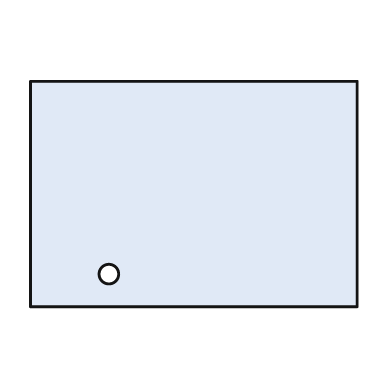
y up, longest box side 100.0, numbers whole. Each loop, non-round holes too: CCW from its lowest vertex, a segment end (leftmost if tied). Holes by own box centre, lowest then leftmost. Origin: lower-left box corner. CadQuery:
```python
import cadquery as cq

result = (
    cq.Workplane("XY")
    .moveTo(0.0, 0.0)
    .lineTo(100.0, 0.0)
    .lineTo(100.0, 69.0)
    .lineTo(0.0, 69.0)
    .close()
    .moveTo(24.0, 10.0)
    .circle(3.0)
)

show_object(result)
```